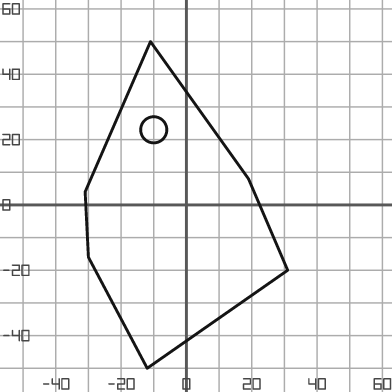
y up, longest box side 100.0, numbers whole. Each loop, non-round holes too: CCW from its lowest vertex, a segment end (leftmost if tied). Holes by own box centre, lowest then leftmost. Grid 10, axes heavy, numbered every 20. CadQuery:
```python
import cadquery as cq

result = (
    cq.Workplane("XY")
    .moveTo(-12.0, -50.0)
    .lineTo(31.0, -20.0)
    .lineTo(19.0, 8.0)
    .lineTo(-11.0, 50.0)
    .lineTo(-31.0, 4.0)
    .lineTo(-30.0, -16.0)
    .close()
    .moveTo(-10.0, 23.0)
    .circle(4.0)
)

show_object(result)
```